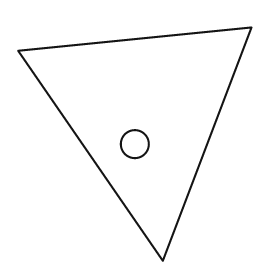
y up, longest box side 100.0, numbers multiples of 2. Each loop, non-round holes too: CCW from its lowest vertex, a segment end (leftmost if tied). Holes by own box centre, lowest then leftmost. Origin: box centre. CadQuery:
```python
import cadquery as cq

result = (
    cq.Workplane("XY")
    .moveTo(12.0, -50.0)
    .lineTo(50.0, 50.0)
    .lineTo(-50.0, 40.0)
    .close()
    .moveTo(0.0, 0.0)
    .circle(6.0)
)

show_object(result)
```